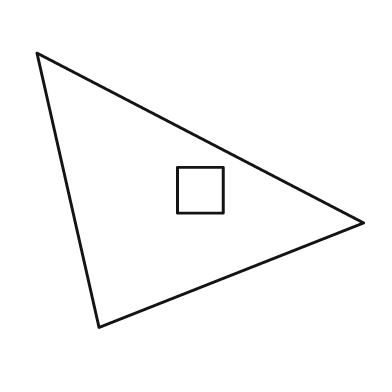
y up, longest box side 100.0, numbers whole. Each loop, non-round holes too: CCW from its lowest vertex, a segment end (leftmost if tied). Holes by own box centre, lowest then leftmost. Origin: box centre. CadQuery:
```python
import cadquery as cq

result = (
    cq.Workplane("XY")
    .moveTo(-31.0, -42.0)
    .lineTo(50.0, -10.0)
    .lineTo(-50.0, 42.0)
    .close()
    .moveTo(-7.0, -7.0)
    .lineTo(7.0, -7.0)
    .lineTo(7.0, 7.0)
    .lineTo(-7.0, 7.0)
    .close()
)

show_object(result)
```